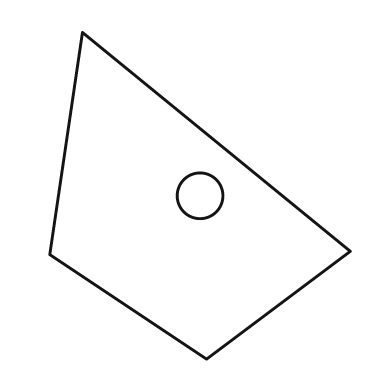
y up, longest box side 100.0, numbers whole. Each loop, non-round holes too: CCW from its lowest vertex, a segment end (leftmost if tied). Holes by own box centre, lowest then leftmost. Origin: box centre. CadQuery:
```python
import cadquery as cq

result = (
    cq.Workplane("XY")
    .moveTo(2.0, -50.0)
    .lineTo(46.0, -17.0)
    .lineTo(-36.0, 50.0)
    .lineTo(-46.0, -18.0)
    .close()
    .moveTo(0.0, 0.0)
    .circle(7.0)
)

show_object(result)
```